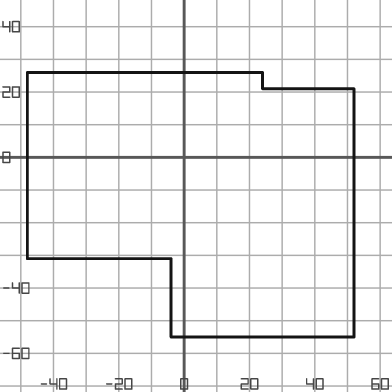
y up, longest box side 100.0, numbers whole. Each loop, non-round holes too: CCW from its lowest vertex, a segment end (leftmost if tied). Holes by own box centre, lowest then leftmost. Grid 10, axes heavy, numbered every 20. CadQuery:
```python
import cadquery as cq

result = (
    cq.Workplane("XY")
    .moveTo(-4.0, -55.0)
    .lineTo(52.0, -55.0)
    .lineTo(52.0, 21.0)
    .lineTo(24.0, 21.0)
    .lineTo(24.0, 26.0)
    .lineTo(-48.0, 26.0)
    .lineTo(-48.0, -31.0)
    .lineTo(-4.0, -31.0)
    .close()
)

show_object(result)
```